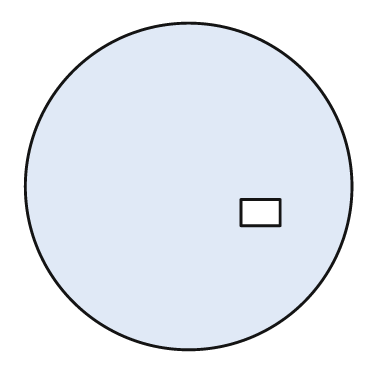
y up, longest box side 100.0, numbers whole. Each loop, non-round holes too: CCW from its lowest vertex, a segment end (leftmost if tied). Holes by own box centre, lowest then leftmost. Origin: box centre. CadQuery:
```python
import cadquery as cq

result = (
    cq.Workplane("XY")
    .moveTo(0.0, 0.0)
    .circle(50.0)
    .moveTo(16.0, -12.0)
    .lineTo(28.0, -12.0)
    .lineTo(28.0, -4.0)
    .lineTo(16.0, -4.0)
    .close()
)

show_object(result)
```